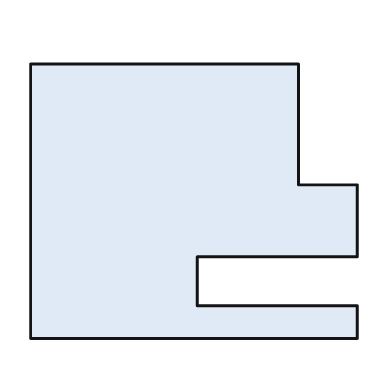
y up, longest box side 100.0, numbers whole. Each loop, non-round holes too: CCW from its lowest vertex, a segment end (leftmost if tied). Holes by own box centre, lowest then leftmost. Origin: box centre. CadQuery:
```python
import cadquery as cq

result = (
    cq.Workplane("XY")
    .moveTo(-50.0, -42.0)
    .lineTo(50.0, -42.0)
    .lineTo(50.0, -32.0)
    .lineTo(1.0, -32.0)
    .lineTo(1.0, -17.0)
    .lineTo(50.0, -17.0)
    .lineTo(50.0, 5.0)
    .lineTo(32.0, 5.0)
    .lineTo(32.0, 42.0)
    .lineTo(-50.0, 42.0)
    .close()
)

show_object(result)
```